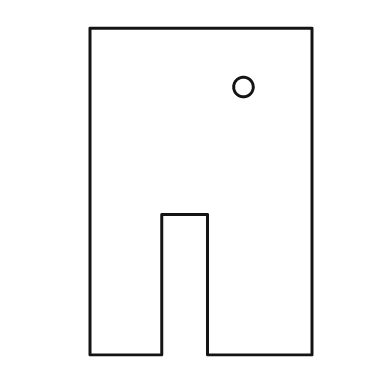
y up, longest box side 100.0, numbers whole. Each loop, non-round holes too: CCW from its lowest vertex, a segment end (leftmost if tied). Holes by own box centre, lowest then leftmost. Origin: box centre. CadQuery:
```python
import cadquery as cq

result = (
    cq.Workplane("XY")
    .moveTo(-34.0, -50.0)
    .lineTo(-12.0, -50.0)
    .lineTo(-12.0, -7.0)
    .lineTo(2.0, -7.0)
    .lineTo(2.0, -50.0)
    .lineTo(34.0, -50.0)
    .lineTo(34.0, 50.0)
    .lineTo(-34.0, 50.0)
    .close()
    .moveTo(13.0, 32.0)
    .circle(3.0)
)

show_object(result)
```